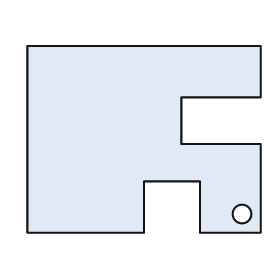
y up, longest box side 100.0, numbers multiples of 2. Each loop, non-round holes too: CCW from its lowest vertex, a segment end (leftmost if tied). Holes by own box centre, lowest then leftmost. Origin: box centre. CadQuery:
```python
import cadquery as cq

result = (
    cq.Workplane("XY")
    .moveTo(-50.0, -40.0)
    .lineTo(0.0, -40.0)
    .lineTo(0.0, -18.0)
    .lineTo(24.0, -18.0)
    .lineTo(24.0, -40.0)
    .lineTo(50.0, -40.0)
    .lineTo(50.0, -2.0)
    .lineTo(16.0, -2.0)
    .lineTo(16.0, 18.0)
    .lineTo(50.0, 18.0)
    .lineTo(50.0, 40.0)
    .lineTo(-50.0, 40.0)
    .close()
    .moveTo(42.0, -32.0)
    .circle(4.0)
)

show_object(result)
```